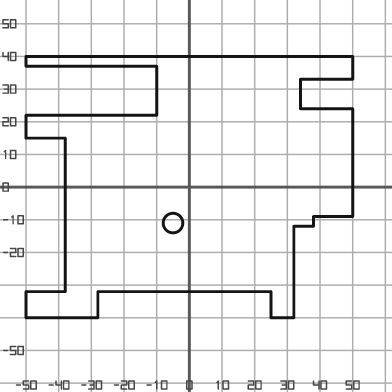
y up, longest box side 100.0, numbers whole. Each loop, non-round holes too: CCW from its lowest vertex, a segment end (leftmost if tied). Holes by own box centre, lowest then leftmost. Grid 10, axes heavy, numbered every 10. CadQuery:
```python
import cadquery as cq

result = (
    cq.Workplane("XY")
    .moveTo(-50.0, -40.0)
    .lineTo(-28.0, -40.0)
    .lineTo(-28.0, -32.0)
    .lineTo(25.0, -32.0)
    .lineTo(25.0, -40.0)
    .lineTo(32.0, -40.0)
    .lineTo(32.0, -12.0)
    .lineTo(38.0, -12.0)
    .lineTo(38.0, -9.0)
    .lineTo(50.0, -9.0)
    .lineTo(50.0, 24.0)
    .lineTo(34.0, 24.0)
    .lineTo(34.0, 33.0)
    .lineTo(50.0, 33.0)
    .lineTo(50.0, 40.0)
    .lineTo(-50.0, 40.0)
    .lineTo(-50.0, 37.0)
    .lineTo(-10.0, 37.0)
    .lineTo(-10.0, 22.0)
    .lineTo(-50.0, 22.0)
    .lineTo(-50.0, 15.0)
    .lineTo(-38.0, 15.0)
    .lineTo(-38.0, -32.0)
    .lineTo(-50.0, -32.0)
    .close()
    .moveTo(-5.0, -11.0)
    .circle(3.0)
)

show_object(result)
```